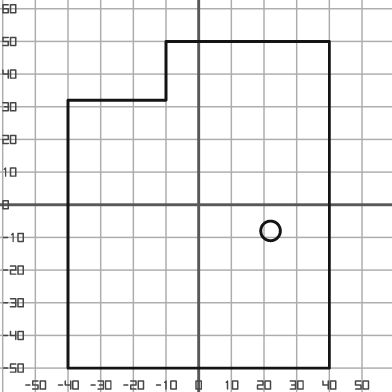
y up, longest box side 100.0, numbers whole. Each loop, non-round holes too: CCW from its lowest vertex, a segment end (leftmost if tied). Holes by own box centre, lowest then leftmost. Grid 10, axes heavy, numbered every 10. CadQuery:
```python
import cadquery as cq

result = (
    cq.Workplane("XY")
    .moveTo(-40.0, -50.0)
    .lineTo(40.0, -50.0)
    .lineTo(40.0, 50.0)
    .lineTo(-10.0, 50.0)
    .lineTo(-10.0, 32.0)
    .lineTo(-40.0, 32.0)
    .close()
    .moveTo(22.0, -8.0)
    .circle(3.0)
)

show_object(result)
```